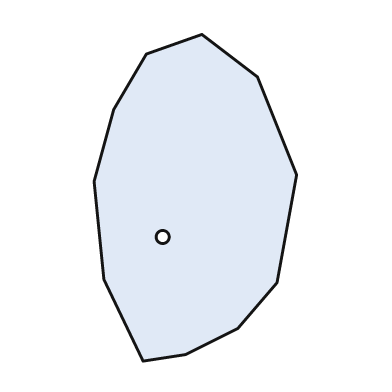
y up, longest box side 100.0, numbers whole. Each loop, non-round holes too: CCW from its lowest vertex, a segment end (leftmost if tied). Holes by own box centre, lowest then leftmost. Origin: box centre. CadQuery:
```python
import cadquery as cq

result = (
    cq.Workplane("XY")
    .moveTo(-16.0, -50.0)
    .lineTo(-3.0, -48.0)
    .lineTo(13.0, -40.0)
    .lineTo(25.0, -26.0)
    .lineTo(31.0, 7.0)
    .lineTo(19.0, 37.0)
    .lineTo(2.0, 50.0)
    .lineTo(-15.0, 44.0)
    .lineTo(-25.0, 27.0)
    .lineTo(-31.0, 5.0)
    .lineTo(-28.0, -25.0)
    .close()
    .moveTo(-10.0, -12.0)
    .circle(2.0)
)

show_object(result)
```